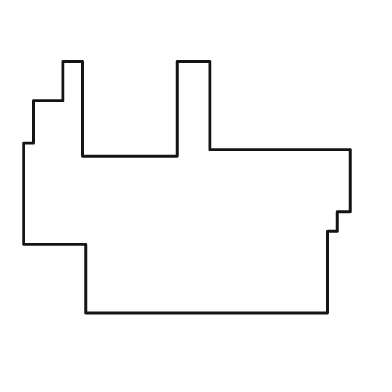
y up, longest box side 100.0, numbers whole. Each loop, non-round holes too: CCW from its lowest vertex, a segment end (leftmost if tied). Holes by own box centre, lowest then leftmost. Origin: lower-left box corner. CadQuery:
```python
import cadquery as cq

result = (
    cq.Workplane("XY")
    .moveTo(19.0, 0.0)
    .lineTo(93.0, 0.0)
    .lineTo(93.0, 25.0)
    .lineTo(96.0, 25.0)
    .lineTo(96.0, 31.0)
    .lineTo(100.0, 31.0)
    .lineTo(100.0, 50.0)
    .lineTo(57.0, 50.0)
    .lineTo(57.0, 77.0)
    .lineTo(47.0, 77.0)
    .lineTo(47.0, 48.0)
    .lineTo(18.0, 48.0)
    .lineTo(18.0, 77.0)
    .lineTo(12.0, 77.0)
    .lineTo(12.0, 65.0)
    .lineTo(3.0, 65.0)
    .lineTo(3.0, 52.0)
    .lineTo(0.0, 52.0)
    .lineTo(0.0, 21.0)
    .lineTo(19.0, 21.0)
    .close()
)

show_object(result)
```